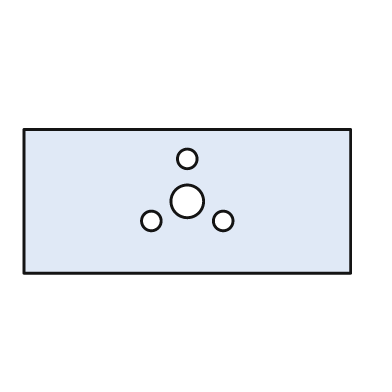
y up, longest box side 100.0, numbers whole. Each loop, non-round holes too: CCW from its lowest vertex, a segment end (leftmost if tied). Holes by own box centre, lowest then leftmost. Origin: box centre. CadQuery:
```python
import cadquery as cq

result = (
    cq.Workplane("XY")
    .moveTo(-50.0, -22.0)
    .lineTo(50.0, -22.0)
    .lineTo(50.0, 22.0)
    .lineTo(-50.0, 22.0)
    .close()
    .moveTo(-11.0, -6.0)
    .circle(3.0)
    .moveTo(11.0, -6.0)
    .circle(3.0)
    .moveTo(0.0, 0.0)
    .circle(5.0)
    .moveTo(0.0, 13.0)
    .circle(3.0)
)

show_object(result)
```